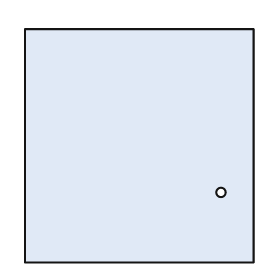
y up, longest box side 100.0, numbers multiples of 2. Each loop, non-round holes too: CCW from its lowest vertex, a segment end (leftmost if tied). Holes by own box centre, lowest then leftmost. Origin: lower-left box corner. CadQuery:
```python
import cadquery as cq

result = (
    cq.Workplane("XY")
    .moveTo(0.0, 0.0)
    .lineTo(98.0, 0.0)
    .lineTo(98.0, 100.0)
    .lineTo(0.0, 100.0)
    .close()
    .moveTo(84.0, 30.0)
    .circle(2.0)
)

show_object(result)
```